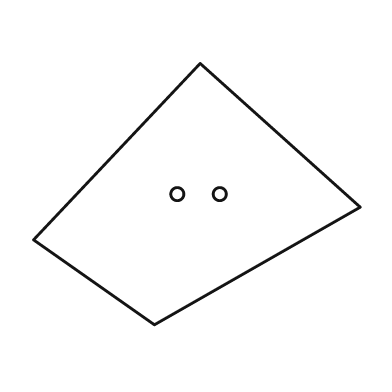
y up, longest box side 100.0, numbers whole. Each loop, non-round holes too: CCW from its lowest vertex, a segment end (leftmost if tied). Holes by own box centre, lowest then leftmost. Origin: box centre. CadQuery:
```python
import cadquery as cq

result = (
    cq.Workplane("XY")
    .moveTo(-13.0, -40.0)
    .lineTo(50.0, -4.0)
    .lineTo(1.0, 40.0)
    .lineTo(-50.0, -14.0)
    .close()
    .moveTo(-6.0, 0.0)
    .circle(2.0)
    .moveTo(7.0, 0.0)
    .circle(2.0)
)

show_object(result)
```